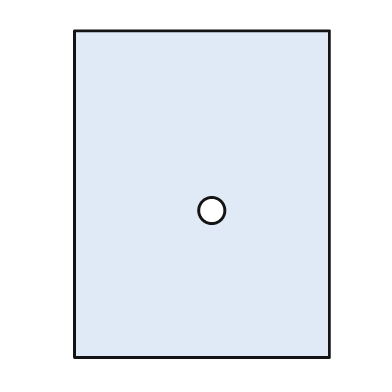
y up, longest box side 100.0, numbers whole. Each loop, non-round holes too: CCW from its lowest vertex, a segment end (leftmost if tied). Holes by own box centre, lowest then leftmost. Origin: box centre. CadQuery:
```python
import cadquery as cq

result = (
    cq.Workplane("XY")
    .moveTo(-39.0, -50.0)
    .lineTo(39.0, -50.0)
    .lineTo(39.0, 50.0)
    .lineTo(-39.0, 50.0)
    .close()
    .moveTo(3.0, -5.0)
    .circle(4.0)
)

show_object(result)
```